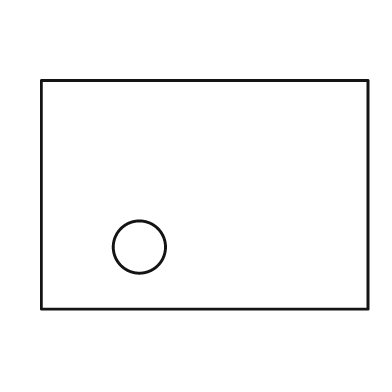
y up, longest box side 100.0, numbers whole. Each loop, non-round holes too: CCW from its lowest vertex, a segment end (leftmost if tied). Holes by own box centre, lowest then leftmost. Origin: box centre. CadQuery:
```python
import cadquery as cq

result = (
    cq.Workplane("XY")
    .moveTo(-50.0, -35.0)
    .lineTo(50.0, -35.0)
    .lineTo(50.0, 35.0)
    .lineTo(-50.0, 35.0)
    .close()
    .moveTo(-20.0, -16.0)
    .circle(8.0)
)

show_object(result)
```